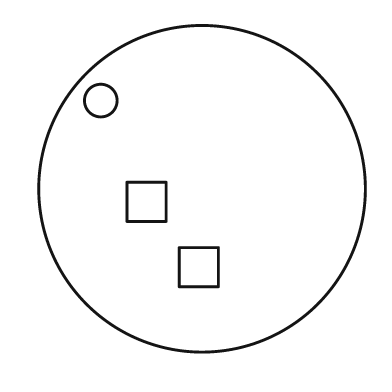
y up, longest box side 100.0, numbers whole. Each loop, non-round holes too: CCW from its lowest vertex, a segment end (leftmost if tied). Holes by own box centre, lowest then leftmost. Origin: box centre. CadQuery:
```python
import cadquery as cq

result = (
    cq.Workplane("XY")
    .moveTo(0.0, 0.0)
    .circle(50.0)
    .moveTo(-7.0, -30.0)
    .lineTo(5.0, -30.0)
    .lineTo(5.0, -18.0)
    .lineTo(-7.0, -18.0)
    .close()
    .moveTo(-23.0, -10.0)
    .lineTo(-11.0, -10.0)
    .lineTo(-11.0, 2.0)
    .lineTo(-23.0, 2.0)
    .close()
    .moveTo(-31.0, 27.0)
    .circle(5.0)
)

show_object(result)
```